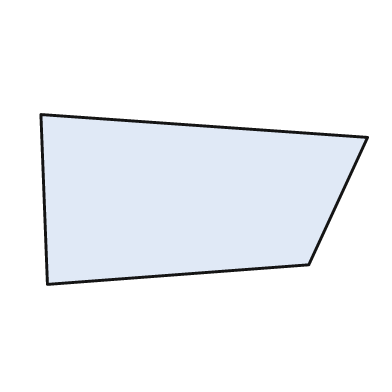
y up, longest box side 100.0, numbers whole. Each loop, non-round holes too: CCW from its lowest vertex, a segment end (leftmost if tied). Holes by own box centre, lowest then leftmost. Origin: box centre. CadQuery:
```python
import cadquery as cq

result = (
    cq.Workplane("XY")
    .moveTo(-48.0, -26.0)
    .lineTo(32.0, -20.0)
    .lineTo(50.0, 19.0)
    .lineTo(-50.0, 26.0)
    .close()
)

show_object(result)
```